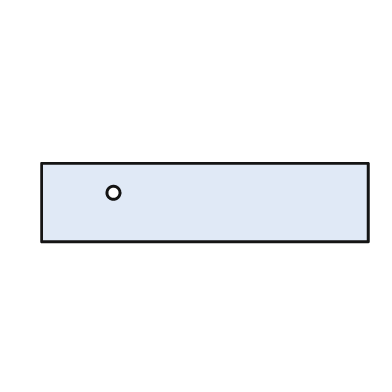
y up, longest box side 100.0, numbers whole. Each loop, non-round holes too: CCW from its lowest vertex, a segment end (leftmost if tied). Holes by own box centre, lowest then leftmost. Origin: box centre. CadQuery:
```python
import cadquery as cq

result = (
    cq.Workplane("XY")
    .moveTo(-50.0, -12.0)
    .lineTo(50.0, -12.0)
    .lineTo(50.0, 12.0)
    .lineTo(-50.0, 12.0)
    .close()
    .moveTo(-28.0, 3.0)
    .circle(2.0)
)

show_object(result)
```